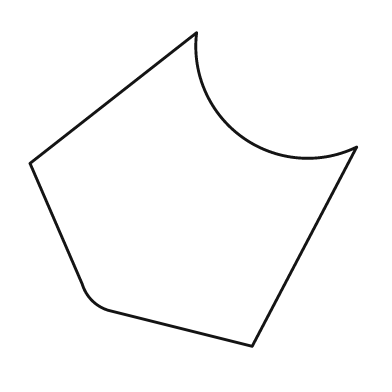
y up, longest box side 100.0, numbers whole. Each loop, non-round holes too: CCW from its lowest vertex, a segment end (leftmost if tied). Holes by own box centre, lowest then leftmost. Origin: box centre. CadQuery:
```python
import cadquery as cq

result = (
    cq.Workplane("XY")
    .moveTo(18.0, -48.0)
    .lineTo(50.0, 13.0)
    .threePointArc((15.0, 16.0), (1.0, 48.0))
    .lineTo(-50.0, 8.0)
    .lineTo(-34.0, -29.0)
    .threePointArc((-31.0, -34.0), (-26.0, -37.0))
    .close()
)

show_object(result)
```